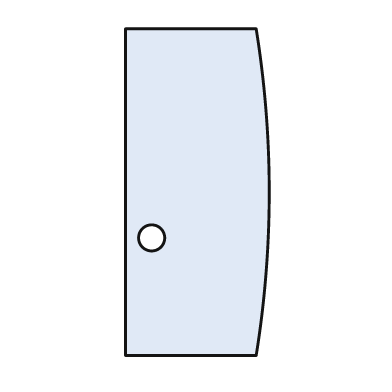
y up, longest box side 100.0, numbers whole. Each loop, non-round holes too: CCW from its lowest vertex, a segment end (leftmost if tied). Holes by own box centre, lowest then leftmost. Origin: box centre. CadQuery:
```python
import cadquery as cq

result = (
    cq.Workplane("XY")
    .moveTo(-22.0, -50.0)
    .lineTo(18.0, -50.0)
    .threePointArc((22.0, 0.0), (18.0, 50.0))
    .lineTo(-22.0, 50.0)
    .close()
    .moveTo(-14.0, -14.0)
    .circle(4.0)
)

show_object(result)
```